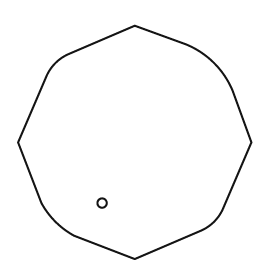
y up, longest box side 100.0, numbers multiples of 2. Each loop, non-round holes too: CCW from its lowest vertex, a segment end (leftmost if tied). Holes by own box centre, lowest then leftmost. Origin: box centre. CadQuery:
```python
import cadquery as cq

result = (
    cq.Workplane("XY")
    .moveTo(0.0, -50.0)
    .lineTo(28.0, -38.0)
    .threePointArc((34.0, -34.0), (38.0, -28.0))
    .lineTo(50.0, 0.0)
    .lineTo(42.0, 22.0)
    .threePointArc((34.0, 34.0), (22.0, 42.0))
    .lineTo(0.0, 50.0)
    .lineTo(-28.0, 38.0)
    .threePointArc((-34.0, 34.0), (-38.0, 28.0))
    .lineTo(-50.0, 0.0)
    .lineTo(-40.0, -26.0)
    .threePointArc((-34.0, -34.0), (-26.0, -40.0))
    .close()
    .moveTo(-14.0, -26.0)
    .circle(2.0)
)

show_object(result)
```